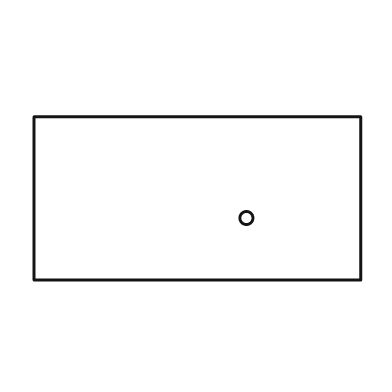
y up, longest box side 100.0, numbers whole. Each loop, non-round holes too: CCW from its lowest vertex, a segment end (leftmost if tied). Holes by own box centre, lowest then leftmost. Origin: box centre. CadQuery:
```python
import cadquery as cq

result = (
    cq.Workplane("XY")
    .moveTo(-50.0, -25.0)
    .lineTo(50.0, -25.0)
    .lineTo(50.0, 25.0)
    .lineTo(-50.0, 25.0)
    .close()
    .moveTo(15.0, -6.0)
    .circle(2.0)
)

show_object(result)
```